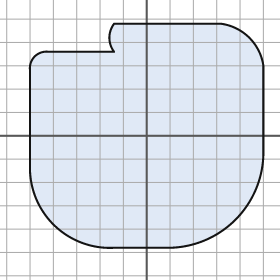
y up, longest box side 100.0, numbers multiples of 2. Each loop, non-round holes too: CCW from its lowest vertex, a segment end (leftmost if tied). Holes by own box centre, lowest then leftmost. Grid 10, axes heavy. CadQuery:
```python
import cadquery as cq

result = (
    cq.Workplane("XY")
    .moveTo(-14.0, -48.0)
    .lineTo(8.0, -48.0)
    .threePointArc((38.0, -36.0), (50.0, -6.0))
    .lineTo(50.0, 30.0)
    .threePointArc((44.0, 42.0), (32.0, 48.0))
    .lineTo(-14.0, 48.0)
    .threePointArc((-16.0, 42.0), (-14.0, 36.0))
    .lineTo(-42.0, 36.0)
    .threePointArc((-48.0, 34.0), (-50.0, 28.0))
    .lineTo(-50.0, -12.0)
    .threePointArc((-40.0, -38.0), (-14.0, -48.0))
    .close()
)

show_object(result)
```